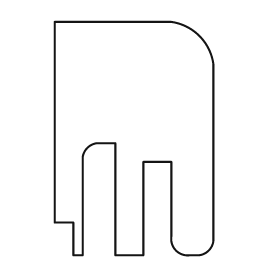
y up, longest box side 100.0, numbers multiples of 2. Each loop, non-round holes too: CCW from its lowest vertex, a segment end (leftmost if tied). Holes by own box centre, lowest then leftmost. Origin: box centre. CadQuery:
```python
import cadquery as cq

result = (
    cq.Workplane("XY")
    .moveTo(-26.0, -50.0)
    .lineTo(-22.0, -50.0)
    .lineTo(-22.0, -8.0)
    .threePointArc((-20.0, -4.0), (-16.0, -2.0))
    .lineTo(-8.0, -2.0)
    .lineTo(-8.0, -50.0)
    .lineTo(4.0, -50.0)
    .lineTo(4.0, -10.0)
    .lineTo(16.0, -10.0)
    .lineTo(16.0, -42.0)
    .threePointArc((18.0, -48.0), (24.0, -50.0))
    .lineTo(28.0, -50.0)
    .threePointArc((32.0, -48.0), (34.0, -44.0))
    .lineTo(34.0, 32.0)
    .threePointArc((28.0, 44.0), (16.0, 50.0))
    .lineTo(-34.0, 50.0)
    .lineTo(-34.0, -36.0)
    .lineTo(-26.0, -36.0)
    .close()
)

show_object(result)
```